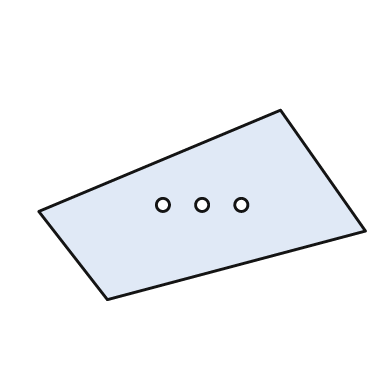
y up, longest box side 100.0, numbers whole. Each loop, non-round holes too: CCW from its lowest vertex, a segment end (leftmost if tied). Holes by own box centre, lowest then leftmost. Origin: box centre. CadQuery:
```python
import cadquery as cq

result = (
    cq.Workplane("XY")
    .moveTo(-29.0, -29.0)
    .lineTo(50.0, -8.0)
    .lineTo(24.0, 29.0)
    .lineTo(-50.0, -2.0)
    .close()
    .moveTo(-12.0, 0.0)
    .circle(2.0)
    .moveTo(0.0, 0.0)
    .circle(2.0)
    .moveTo(12.0, 0.0)
    .circle(2.0)
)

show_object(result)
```